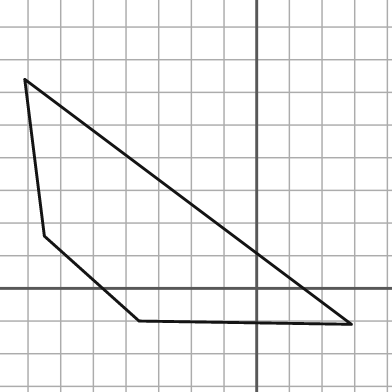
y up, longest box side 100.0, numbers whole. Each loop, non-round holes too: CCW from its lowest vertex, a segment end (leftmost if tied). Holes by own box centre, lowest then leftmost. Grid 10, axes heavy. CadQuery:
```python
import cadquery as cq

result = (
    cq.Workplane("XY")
    .moveTo(29.0, -11.0)
    .lineTo(-71.0, 64.0)
    .lineTo(-65.0, 16.0)
    .lineTo(-36.0, -10.0)
    .close()
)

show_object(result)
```